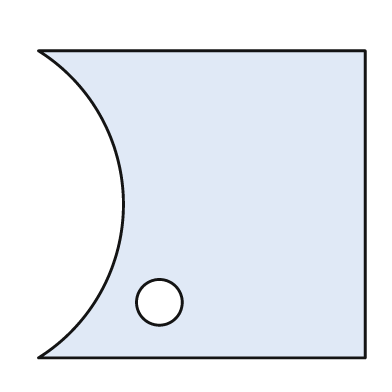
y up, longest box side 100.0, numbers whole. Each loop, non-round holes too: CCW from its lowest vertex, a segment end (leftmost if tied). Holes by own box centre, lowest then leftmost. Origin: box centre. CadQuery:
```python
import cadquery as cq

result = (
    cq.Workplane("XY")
    .moveTo(-50.0, -47.0)
    .lineTo(50.0, -47.0)
    .lineTo(50.0, 47.0)
    .lineTo(-50.0, 47.0)
    .threePointArc((-24.0, 0.0), (-50.0, -47.0))
    .close()
    .moveTo(-13.0, -30.0)
    .circle(7.0)
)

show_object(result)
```